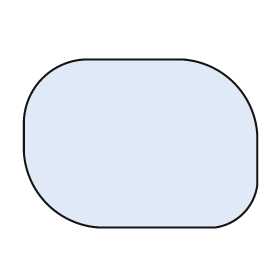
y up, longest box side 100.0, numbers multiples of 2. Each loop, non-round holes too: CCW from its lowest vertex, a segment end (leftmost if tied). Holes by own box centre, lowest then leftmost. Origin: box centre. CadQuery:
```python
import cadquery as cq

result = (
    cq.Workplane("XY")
    .moveTo(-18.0, -36.0)
    .lineTo(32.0, -36.0)
    .threePointArc((44.0, -30.0), (50.0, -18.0))
    .lineTo(50.0, 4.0)
    .threePointArc((40.0, 26.0), (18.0, 36.0))
    .lineTo(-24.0, 36.0)
    .threePointArc((-42.0, 28.0), (-50.0, 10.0))
    .lineTo(-50.0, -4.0)
    .threePointArc((-40.0, -26.0), (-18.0, -36.0))
    .close()
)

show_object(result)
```